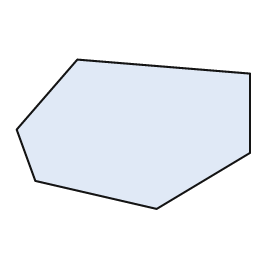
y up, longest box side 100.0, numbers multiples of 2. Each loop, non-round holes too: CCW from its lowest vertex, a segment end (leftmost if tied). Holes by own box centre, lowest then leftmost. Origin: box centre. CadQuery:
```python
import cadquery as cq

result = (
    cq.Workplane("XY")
    .moveTo(10.0, -32.0)
    .lineTo(50.0, -8.0)
    .lineTo(50.0, 26.0)
    .lineTo(-24.0, 32.0)
    .lineTo(-50.0, 2.0)
    .lineTo(-42.0, -20.0)
    .close()
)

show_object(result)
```